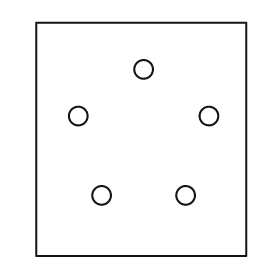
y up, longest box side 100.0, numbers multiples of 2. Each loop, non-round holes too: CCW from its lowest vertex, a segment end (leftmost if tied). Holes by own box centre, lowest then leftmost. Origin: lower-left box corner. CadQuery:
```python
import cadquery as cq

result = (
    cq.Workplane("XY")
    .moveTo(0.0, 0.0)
    .lineTo(90.0, 0.0)
    .lineTo(90.0, 100.0)
    .lineTo(0.0, 100.0)
    .close()
    .moveTo(28.0, 26.0)
    .circle(4.0)
    .moveTo(64.0, 26.0)
    .circle(4.0)
    .moveTo(18.0, 60.0)
    .circle(4.0)
    .moveTo(74.0, 60.0)
    .circle(4.0)
    .moveTo(46.0, 80.0)
    .circle(4.0)
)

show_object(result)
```